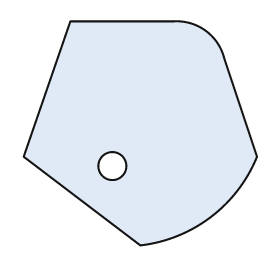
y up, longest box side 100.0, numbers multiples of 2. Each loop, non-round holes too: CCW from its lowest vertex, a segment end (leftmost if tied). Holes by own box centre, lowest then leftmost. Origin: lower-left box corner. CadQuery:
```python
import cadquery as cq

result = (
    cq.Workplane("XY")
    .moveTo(50.0, 0.0)
    .threePointArc((80.0, 12.0), (100.0, 38.0))
    .lineTo(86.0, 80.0)
    .threePointArc((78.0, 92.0), (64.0, 96.0))
    .lineTo(20.0, 96.0)
    .lineTo(0.0, 38.0)
    .close()
    .moveTo(38.0, 34.0)
    .circle(6.0)
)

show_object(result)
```